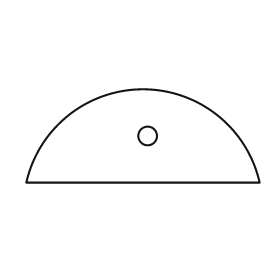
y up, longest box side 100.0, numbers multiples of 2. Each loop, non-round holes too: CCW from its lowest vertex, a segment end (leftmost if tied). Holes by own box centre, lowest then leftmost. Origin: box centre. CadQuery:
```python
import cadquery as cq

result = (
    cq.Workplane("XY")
    .moveTo(-50.0, -20.0)
    .lineTo(50.0, -20.0)
    .threePointArc((0.0, 20.0), (-50.0, -20.0))
    .close()
    .moveTo(2.0, 0.0)
    .circle(4.0)
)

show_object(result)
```